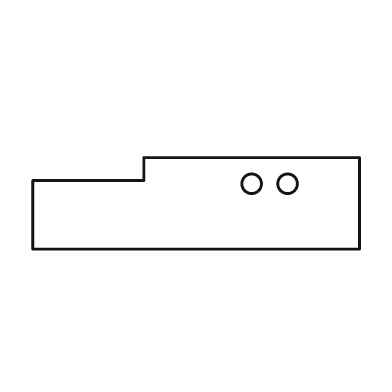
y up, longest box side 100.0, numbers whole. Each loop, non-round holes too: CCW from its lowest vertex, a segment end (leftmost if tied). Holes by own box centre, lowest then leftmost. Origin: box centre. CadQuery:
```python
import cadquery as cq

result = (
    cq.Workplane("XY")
    .moveTo(-50.0, -14.0)
    .lineTo(50.0, -14.0)
    .lineTo(50.0, 14.0)
    .lineTo(-16.0, 14.0)
    .lineTo(-16.0, 7.0)
    .lineTo(-50.0, 7.0)
    .close()
    .moveTo(17.0, 6.0)
    .circle(3.0)
    .moveTo(28.0, 6.0)
    .circle(3.0)
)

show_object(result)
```